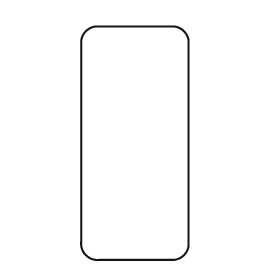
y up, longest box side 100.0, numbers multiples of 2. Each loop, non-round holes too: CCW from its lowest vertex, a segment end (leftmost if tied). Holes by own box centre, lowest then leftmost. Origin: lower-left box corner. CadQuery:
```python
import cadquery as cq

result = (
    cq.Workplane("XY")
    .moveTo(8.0, 0.0)
    .lineTo(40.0, 0.0)
    .threePointArc((44.0, 2.0), (46.0, 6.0))
    .lineTo(46.0, 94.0)
    .threePointArc((44.0, 98.0), (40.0, 100.0))
    .lineTo(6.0, 100.0)
    .threePointArc((2.0, 98.0), (0.0, 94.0))
    .lineTo(0.0, 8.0)
    .threePointArc((2.0, 2.0), (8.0, 0.0))
    .close()
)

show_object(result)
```